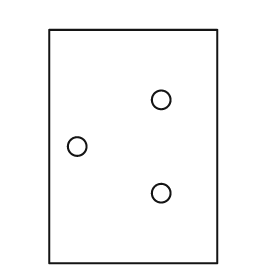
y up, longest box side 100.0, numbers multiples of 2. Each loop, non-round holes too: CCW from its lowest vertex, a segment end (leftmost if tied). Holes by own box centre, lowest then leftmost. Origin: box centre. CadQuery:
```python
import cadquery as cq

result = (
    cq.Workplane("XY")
    .moveTo(-36.0, -50.0)
    .lineTo(36.0, -50.0)
    .lineTo(36.0, 50.0)
    .lineTo(-36.0, 50.0)
    .close()
    .moveTo(12.0, -20.0)
    .circle(4.0)
    .moveTo(-24.0, 0.0)
    .circle(4.0)
    .moveTo(12.0, 20.0)
    .circle(4.0)
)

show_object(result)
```